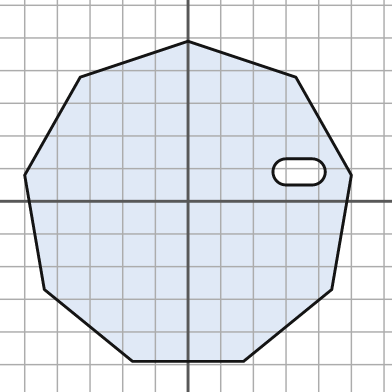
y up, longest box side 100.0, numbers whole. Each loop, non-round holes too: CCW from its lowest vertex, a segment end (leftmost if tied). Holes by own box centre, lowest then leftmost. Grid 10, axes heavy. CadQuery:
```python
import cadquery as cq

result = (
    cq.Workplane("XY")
    .moveTo(-17.0, -49.0)
    .lineTo(17.0, -49.0)
    .lineTo(44.0, -27.0)
    .lineTo(50.0, 8.0)
    .lineTo(33.0, 38.0)
    .lineTo(0.0, 49.0)
    .lineTo(-33.0, 38.0)
    .lineTo(-50.0, 8.0)
    .lineTo(-44.0, -27.0)
    .close()
    .moveTo(30.0, 5.0)
    .lineTo(38.0, 5.0)
    .threePointArc((42.0, 9.0), (38.0, 13.0))
    .lineTo(30.0, 13.0)
    .threePointArc((26.0, 9.0), (30.0, 5.0))
    .close()
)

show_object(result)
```